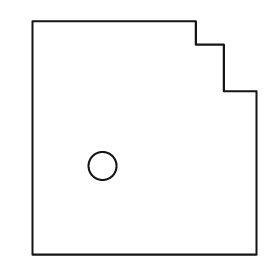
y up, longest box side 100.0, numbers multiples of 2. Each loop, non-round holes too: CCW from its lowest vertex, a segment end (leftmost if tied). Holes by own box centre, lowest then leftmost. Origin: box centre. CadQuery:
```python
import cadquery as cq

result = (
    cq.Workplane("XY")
    .moveTo(-48.0, -50.0)
    .lineTo(48.0, -50.0)
    .lineTo(48.0, 20.0)
    .lineTo(34.0, 20.0)
    .lineTo(34.0, 40.0)
    .lineTo(22.0, 40.0)
    .lineTo(22.0, 50.0)
    .lineTo(-48.0, 50.0)
    .close()
    .moveTo(-18.0, -12.0)
    .circle(6.0)
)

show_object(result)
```